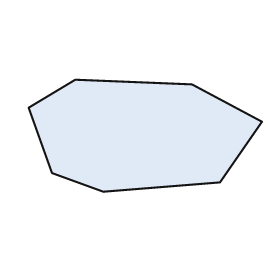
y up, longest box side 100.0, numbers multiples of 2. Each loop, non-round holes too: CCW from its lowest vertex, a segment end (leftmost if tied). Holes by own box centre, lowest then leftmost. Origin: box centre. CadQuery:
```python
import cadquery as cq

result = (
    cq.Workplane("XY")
    .moveTo(-18.0, -24.0)
    .lineTo(32.0, -20.0)
    .lineTo(50.0, 6.0)
    .lineTo(20.0, 22.0)
    .lineTo(-30.0, 24.0)
    .lineTo(-50.0, 12.0)
    .lineTo(-40.0, -16.0)
    .close()
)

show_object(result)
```